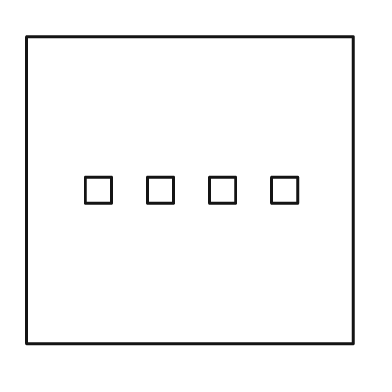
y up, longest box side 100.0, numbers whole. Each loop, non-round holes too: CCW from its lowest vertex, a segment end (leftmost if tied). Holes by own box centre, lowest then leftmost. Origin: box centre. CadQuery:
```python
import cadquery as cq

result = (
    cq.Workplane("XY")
    .moveTo(-50.0, -47.0)
    .lineTo(50.0, -47.0)
    .lineTo(50.0, 47.0)
    .lineTo(-50.0, 47.0)
    .close()
    .moveTo(-32.0, -4.0)
    .lineTo(-24.0, -4.0)
    .lineTo(-24.0, 4.0)
    .lineTo(-32.0, 4.0)
    .close()
    .moveTo(-13.0, -4.0)
    .lineTo(-5.0, -4.0)
    .lineTo(-5.0, 4.0)
    .lineTo(-13.0, 4.0)
    .close()
    .moveTo(6.0, -4.0)
    .lineTo(14.0, -4.0)
    .lineTo(14.0, 4.0)
    .lineTo(6.0, 4.0)
    .close()
    .moveTo(25.0, -4.0)
    .lineTo(33.0, -4.0)
    .lineTo(33.0, 4.0)
    .lineTo(25.0, 4.0)
    .close()
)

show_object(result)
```